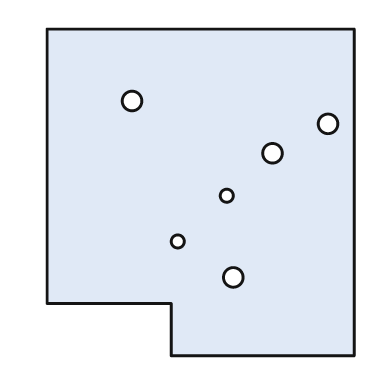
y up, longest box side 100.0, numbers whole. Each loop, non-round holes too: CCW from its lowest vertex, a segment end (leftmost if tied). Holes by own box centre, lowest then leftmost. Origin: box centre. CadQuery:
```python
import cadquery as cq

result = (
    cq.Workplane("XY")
    .moveTo(-9.0, -50.0)
    .lineTo(47.0, -50.0)
    .lineTo(47.0, 50.0)
    .lineTo(-47.0, 50.0)
    .lineTo(-47.0, -34.0)
    .lineTo(-9.0, -34.0)
    .close()
    .moveTo(10.0, -26.0)
    .circle(3.0)
    .moveTo(-7.0, -15.0)
    .circle(2.0)
    .moveTo(8.0, -1.0)
    .circle(2.0)
    .moveTo(22.0, 12.0)
    .circle(3.0)
    .moveTo(39.0, 21.0)
    .circle(3.0)
    .moveTo(-21.0, 28.0)
    .circle(3.0)
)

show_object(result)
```